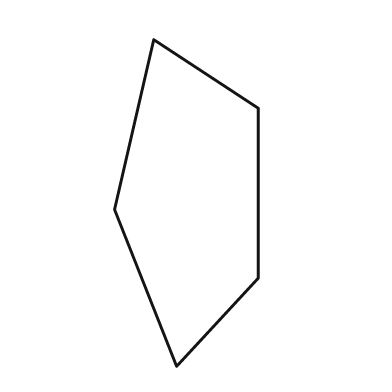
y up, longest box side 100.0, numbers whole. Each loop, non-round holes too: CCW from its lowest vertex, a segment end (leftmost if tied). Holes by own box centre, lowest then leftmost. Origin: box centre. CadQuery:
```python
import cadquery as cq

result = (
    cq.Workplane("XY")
    .moveTo(-3.0, -50.0)
    .lineTo(22.0, -23.0)
    .lineTo(22.0, 29.0)
    .lineTo(-10.0, 50.0)
    .lineTo(-22.0, -2.0)
    .close()
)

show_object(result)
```